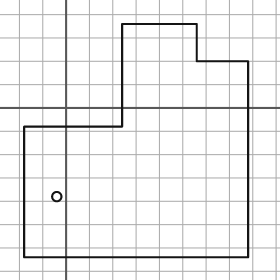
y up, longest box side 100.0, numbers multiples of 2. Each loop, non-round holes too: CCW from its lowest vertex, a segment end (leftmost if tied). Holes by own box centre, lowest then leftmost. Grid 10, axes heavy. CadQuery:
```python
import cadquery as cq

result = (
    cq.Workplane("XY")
    .moveTo(-18.0, -64.0)
    .lineTo(78.0, -64.0)
    .lineTo(78.0, 20.0)
    .lineTo(56.0, 20.0)
    .lineTo(56.0, 36.0)
    .lineTo(24.0, 36.0)
    .lineTo(24.0, -8.0)
    .lineTo(-18.0, -8.0)
    .close()
    .moveTo(-4.0, -38.0)
    .circle(2.0)
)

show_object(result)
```